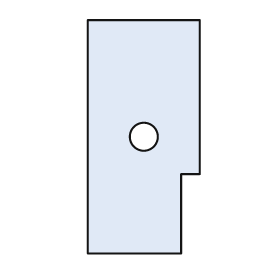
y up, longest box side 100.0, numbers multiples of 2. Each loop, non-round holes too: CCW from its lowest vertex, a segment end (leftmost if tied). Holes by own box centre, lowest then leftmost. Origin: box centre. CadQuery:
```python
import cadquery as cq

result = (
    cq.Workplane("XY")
    .moveTo(-24.0, -50.0)
    .lineTo(16.0, -50.0)
    .lineTo(16.0, -16.0)
    .lineTo(24.0, -16.0)
    .lineTo(24.0, 50.0)
    .lineTo(-24.0, 50.0)
    .close()
    .moveTo(0.0, 0.0)
    .circle(6.0)
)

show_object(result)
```